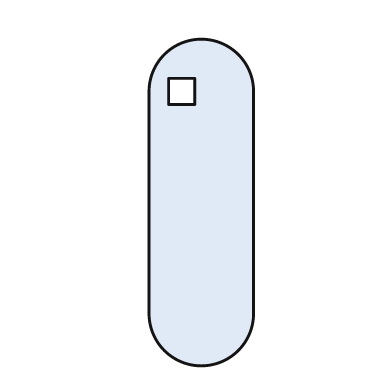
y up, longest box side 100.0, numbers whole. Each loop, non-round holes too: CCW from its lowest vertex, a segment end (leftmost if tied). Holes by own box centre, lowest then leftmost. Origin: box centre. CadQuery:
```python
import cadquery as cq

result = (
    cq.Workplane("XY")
    .moveTo(-16.0, -34.0)
    .threePointArc((0.0, -50.0), (16.0, -34.0))
    .lineTo(16.0, 34.0)
    .threePointArc((0.0, 50.0), (-16.0, 34.0))
    .close()
    .moveTo(-10.0, 30.0)
    .lineTo(-2.0, 30.0)
    .lineTo(-2.0, 38.0)
    .lineTo(-10.0, 38.0)
    .close()
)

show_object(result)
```